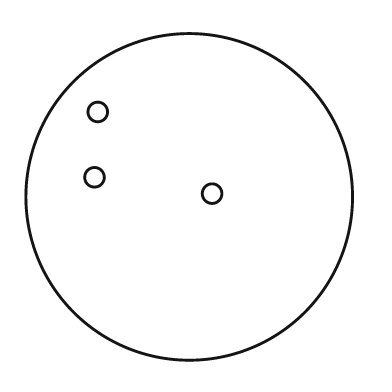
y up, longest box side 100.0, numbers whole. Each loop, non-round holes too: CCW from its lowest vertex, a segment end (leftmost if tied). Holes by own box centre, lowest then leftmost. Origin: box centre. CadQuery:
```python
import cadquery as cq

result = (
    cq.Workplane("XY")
    .moveTo(0.0, 0.0)
    .circle(50.0)
    .moveTo(7.0, 1.0)
    .circle(3.0)
    .moveTo(-29.0, 6.0)
    .circle(3.0)
    .moveTo(-28.0, 26.0)
    .circle(3.0)
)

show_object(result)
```